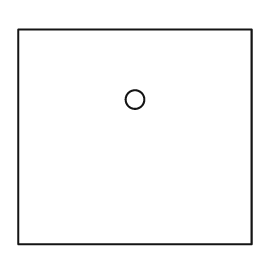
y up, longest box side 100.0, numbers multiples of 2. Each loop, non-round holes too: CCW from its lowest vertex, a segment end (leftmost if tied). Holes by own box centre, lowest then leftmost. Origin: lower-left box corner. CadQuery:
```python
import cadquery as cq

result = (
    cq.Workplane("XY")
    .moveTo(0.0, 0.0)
    .lineTo(100.0, 0.0)
    .lineTo(100.0, 92.0)
    .lineTo(0.0, 92.0)
    .close()
    .moveTo(50.0, 62.0)
    .circle(4.0)
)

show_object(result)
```